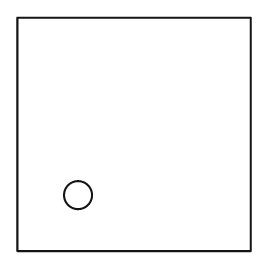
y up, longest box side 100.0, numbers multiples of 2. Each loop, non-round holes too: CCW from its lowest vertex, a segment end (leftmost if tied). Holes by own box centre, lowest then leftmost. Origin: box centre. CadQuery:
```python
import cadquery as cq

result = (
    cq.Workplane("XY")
    .moveTo(-50.0, -50.0)
    .lineTo(50.0, -50.0)
    .lineTo(50.0, 50.0)
    .lineTo(-50.0, 50.0)
    .close()
    .moveTo(-24.0, -26.0)
    .circle(6.0)
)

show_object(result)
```